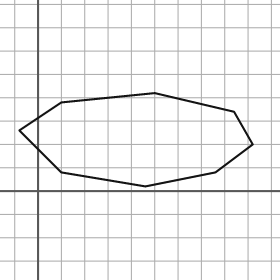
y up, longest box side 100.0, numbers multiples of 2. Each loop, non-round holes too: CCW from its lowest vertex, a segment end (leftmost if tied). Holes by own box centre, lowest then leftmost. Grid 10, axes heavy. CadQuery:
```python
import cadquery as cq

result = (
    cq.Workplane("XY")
    .moveTo(46.0, 2.0)
    .lineTo(76.0, 8.0)
    .lineTo(92.0, 20.0)
    .lineTo(84.0, 34.0)
    .lineTo(50.0, 42.0)
    .lineTo(10.0, 38.0)
    .lineTo(-8.0, 26.0)
    .lineTo(10.0, 8.0)
    .close()
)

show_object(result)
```